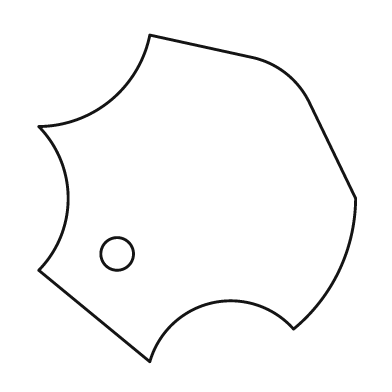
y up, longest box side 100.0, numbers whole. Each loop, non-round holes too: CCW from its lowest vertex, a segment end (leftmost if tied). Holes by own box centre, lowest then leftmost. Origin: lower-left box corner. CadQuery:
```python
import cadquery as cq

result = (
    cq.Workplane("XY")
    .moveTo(34.0, 0.0)
    .threePointArc((53.0, 18.0), (78.0, 10.0))
    .threePointArc((92.0, 28.0), (97.0, 50.0))
    .lineTo(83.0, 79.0)
    .threePointArc((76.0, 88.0), (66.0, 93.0))
    .lineTo(34.0, 100.0)
    .threePointArc((22.0, 80.0), (0.0, 72.0))
    .threePointArc((9.0, 50.0), (0.0, 28.0))
    .close()
    .moveTo(24.0, 33.0)
    .circle(5.0)
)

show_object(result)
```